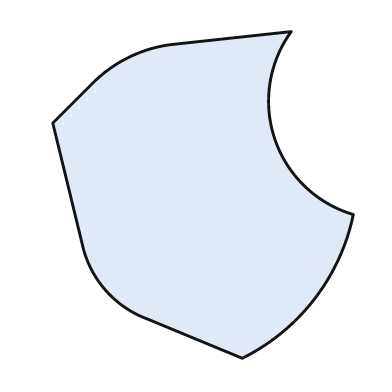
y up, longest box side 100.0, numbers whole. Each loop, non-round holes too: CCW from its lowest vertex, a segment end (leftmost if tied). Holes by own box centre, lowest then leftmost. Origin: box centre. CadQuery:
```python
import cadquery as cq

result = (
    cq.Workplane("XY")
    .moveTo(12.0, -50.0)
    .threePointArc((34.0, -32.0), (46.0, -6.0))
    .threePointArc((22.0, 17.0), (27.0, 50.0))
    .lineTo(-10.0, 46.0)
    .threePointArc((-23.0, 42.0), (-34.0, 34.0))
    .lineTo(-46.0, 22.0)
    .lineTo(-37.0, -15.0)
    .threePointArc((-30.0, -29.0), (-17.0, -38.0))
    .close()
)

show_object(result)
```